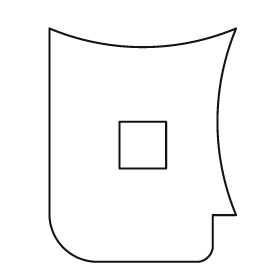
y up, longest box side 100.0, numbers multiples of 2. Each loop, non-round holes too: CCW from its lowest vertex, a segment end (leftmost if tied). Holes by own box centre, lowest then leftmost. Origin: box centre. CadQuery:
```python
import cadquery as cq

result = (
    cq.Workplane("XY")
    .moveTo(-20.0, -50.0)
    .lineTo(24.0, -50.0)
    .threePointArc((28.0, -48.0), (30.0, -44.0))
    .lineTo(30.0, -30.0)
    .lineTo(40.0, -30.0)
    .threePointArc((32.0, 10.0), (40.0, 50.0))
    .threePointArc((0.0, 42.0), (-40.0, 50.0))
    .lineTo(-40.0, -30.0)
    .threePointArc((-34.0, -44.0), (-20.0, -50.0))
    .close()
    .moveTo(-10.0, -10.0)
    .lineTo(10.0, -10.0)
    .lineTo(10.0, 10.0)
    .lineTo(-10.0, 10.0)
    .close()
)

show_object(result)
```